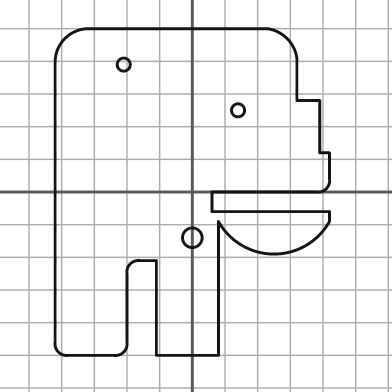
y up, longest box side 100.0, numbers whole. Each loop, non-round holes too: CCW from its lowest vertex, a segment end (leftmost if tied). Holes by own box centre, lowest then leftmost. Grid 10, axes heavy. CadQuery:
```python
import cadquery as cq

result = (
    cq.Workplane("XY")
    .moveTo(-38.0, -50.0)
    .lineTo(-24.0, -50.0)
    .threePointArc((-21.0, -49.0), (-20.0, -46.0))
    .lineTo(-20.0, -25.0)
    .threePointArc((-19.0, -22.0), (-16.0, -21.0))
    .lineTo(-11.0, -21.0)
    .lineTo(-11.0, -50.0)
    .lineTo(8.0, -50.0)
    .lineTo(8.0, -9.0)
    .threePointArc((25.0, -19.0), (42.0, -9.0))
    .lineTo(42.0, -6.0)
    .lineTo(6.0, -6.0)
    .lineTo(6.0, 0.0)
    .lineTo(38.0, 0.0)
    .threePointArc((41.0, 1.0), (42.0, 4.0))
    .lineTo(42.0, 12.0)
    .lineTo(39.0, 12.0)
    .lineTo(39.0, 28.0)
    .lineTo(32.0, 28.0)
    .lineTo(32.0, 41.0)
    .threePointArc((29.0, 47.0), (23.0, 50.0))
    .lineTo(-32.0, 50.0)
    .threePointArc((-39.0, 47.0), (-42.0, 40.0))
    .lineTo(-42.0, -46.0)
    .threePointArc((-41.0, -49.0), (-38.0, -50.0))
    .close()
    .moveTo(0.0, -14.0)
    .circle(3.0)
    .moveTo(14.0, 25.0)
    .circle(2.0)
    .moveTo(-21.0, 39.0)
    .circle(2.0)
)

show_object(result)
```